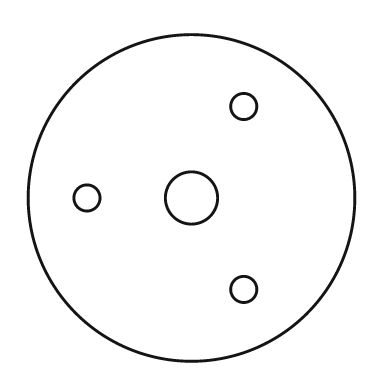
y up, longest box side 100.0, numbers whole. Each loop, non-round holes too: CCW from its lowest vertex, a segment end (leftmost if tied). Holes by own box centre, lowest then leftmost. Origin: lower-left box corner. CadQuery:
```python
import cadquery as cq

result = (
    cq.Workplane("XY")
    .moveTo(50.0, 50.0)
    .circle(50.0)
    .moveTo(66.0, 22.0)
    .circle(4.0)
    .moveTo(18.0, 50.0)
    .circle(4.0)
    .moveTo(50.0, 50.0)
    .circle(8.0)
    .moveTo(66.0, 78.0)
    .circle(4.0)
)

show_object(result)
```